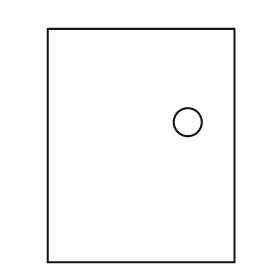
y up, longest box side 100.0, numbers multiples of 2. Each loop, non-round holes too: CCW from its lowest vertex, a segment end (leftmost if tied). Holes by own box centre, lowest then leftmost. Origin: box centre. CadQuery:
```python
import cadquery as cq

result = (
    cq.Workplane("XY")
    .moveTo(-40.0, -50.0)
    .lineTo(40.0, -50.0)
    .lineTo(40.0, 50.0)
    .lineTo(-40.0, 50.0)
    .close()
    .moveTo(20.0, 10.0)
    .circle(6.0)
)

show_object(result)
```